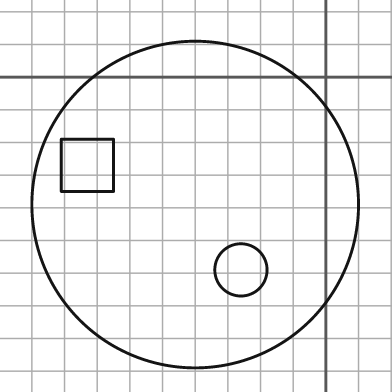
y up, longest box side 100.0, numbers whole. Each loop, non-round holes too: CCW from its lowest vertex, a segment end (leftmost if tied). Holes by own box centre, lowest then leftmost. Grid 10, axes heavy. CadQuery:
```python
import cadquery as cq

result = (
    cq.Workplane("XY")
    .moveTo(-40.0, -39.0)
    .circle(50.0)
    .moveTo(-26.0, -59.0)
    .circle(8.0)
    .moveTo(-81.0, -35.0)
    .lineTo(-65.0, -35.0)
    .lineTo(-65.0, -19.0)
    .lineTo(-81.0, -19.0)
    .close()
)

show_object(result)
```